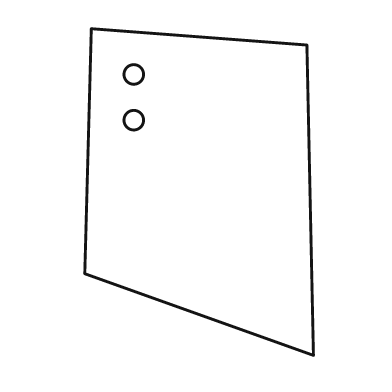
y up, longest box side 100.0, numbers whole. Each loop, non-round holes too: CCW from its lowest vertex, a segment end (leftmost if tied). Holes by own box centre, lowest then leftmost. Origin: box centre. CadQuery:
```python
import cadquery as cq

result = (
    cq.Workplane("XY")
    .moveTo(35.0, -50.0)
    .lineTo(33.0, 45.0)
    .lineTo(-33.0, 50.0)
    .lineTo(-35.0, -25.0)
    .close()
    .moveTo(-20.0, 22.0)
    .circle(3.0)
    .moveTo(-20.0, 36.0)
    .circle(3.0)
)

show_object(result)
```